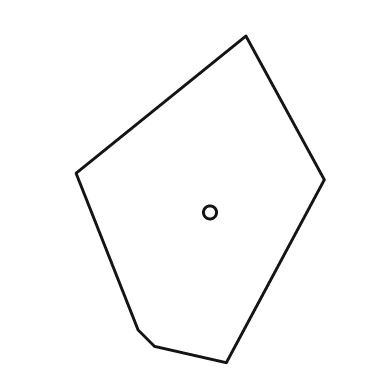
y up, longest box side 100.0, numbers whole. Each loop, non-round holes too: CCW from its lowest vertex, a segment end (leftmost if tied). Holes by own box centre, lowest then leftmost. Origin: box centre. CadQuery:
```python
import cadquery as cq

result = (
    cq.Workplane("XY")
    .moveTo(8.0, -50.0)
    .lineTo(38.0, 6.0)
    .lineTo(14.0, 50.0)
    .lineTo(-38.0, 8.0)
    .lineTo(-19.0, -40.0)
    .lineTo(-14.0, -45.0)
    .close()
    .moveTo(3.0, -4.0)
    .circle(2.0)
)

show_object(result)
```